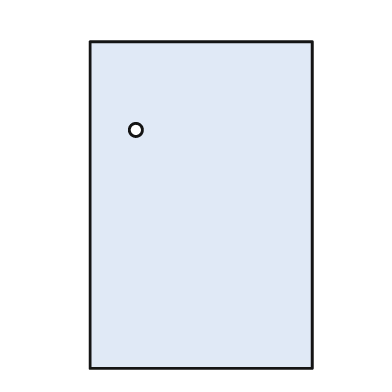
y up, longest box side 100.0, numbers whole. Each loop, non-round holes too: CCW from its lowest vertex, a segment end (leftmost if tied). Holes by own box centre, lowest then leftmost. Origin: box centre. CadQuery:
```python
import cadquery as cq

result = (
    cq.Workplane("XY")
    .moveTo(-34.0, -50.0)
    .lineTo(34.0, -50.0)
    .lineTo(34.0, 50.0)
    .lineTo(-34.0, 50.0)
    .close()
    .moveTo(-20.0, 23.0)
    .circle(2.0)
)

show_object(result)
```